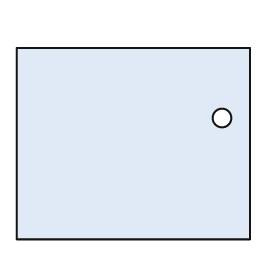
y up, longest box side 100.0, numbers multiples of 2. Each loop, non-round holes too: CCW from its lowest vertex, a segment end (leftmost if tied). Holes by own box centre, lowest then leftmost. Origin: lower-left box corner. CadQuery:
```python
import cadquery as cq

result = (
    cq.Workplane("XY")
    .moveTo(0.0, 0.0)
    .lineTo(100.0, 0.0)
    .lineTo(100.0, 82.0)
    .lineTo(0.0, 82.0)
    .close()
    .moveTo(88.0, 52.0)
    .circle(4.0)
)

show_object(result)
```